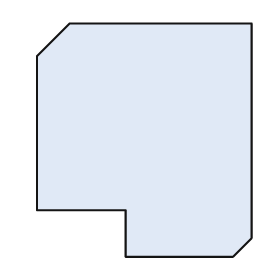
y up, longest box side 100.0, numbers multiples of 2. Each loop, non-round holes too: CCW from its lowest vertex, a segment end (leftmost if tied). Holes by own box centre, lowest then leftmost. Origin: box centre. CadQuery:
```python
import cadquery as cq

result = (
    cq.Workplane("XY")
    .moveTo(-8.0, -50.0)
    .lineTo(38.0, -50.0)
    .lineTo(46.0, -42.0)
    .lineTo(46.0, 50.0)
    .lineTo(-32.0, 50.0)
    .lineTo(-46.0, 36.0)
    .lineTo(-46.0, -30.0)
    .lineTo(-8.0, -30.0)
    .close()
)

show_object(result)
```